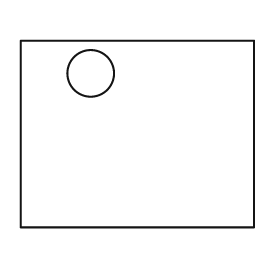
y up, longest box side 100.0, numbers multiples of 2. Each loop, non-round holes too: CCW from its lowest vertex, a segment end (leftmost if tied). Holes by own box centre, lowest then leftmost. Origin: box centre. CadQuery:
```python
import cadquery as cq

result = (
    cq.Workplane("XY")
    .moveTo(-50.0, -40.0)
    .lineTo(50.0, -40.0)
    .lineTo(50.0, 40.0)
    .lineTo(-50.0, 40.0)
    .close()
    .moveTo(-20.0, 26.0)
    .circle(10.0)
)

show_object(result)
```